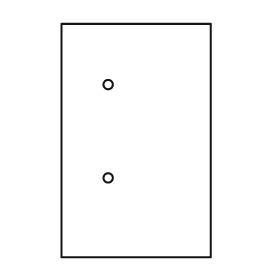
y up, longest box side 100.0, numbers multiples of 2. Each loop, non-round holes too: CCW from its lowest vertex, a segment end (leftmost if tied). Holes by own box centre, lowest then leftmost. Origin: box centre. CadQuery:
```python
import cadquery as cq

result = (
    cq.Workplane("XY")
    .moveTo(-32.0, -50.0)
    .lineTo(32.0, -50.0)
    .lineTo(32.0, 50.0)
    .lineTo(-32.0, 50.0)
    .close()
    .moveTo(-12.0, -16.0)
    .circle(2.0)
    .moveTo(-12.0, 24.0)
    .circle(2.0)
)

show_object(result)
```